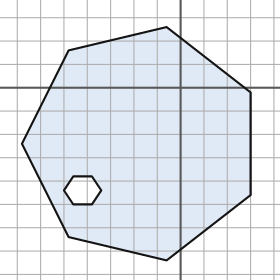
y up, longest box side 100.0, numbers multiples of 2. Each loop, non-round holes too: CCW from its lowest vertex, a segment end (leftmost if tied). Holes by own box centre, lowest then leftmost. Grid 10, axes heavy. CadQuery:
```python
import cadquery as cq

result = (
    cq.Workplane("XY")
    .moveTo(-6.0, -74.0)
    .lineTo(30.0, -46.0)
    .lineTo(30.0, -2.0)
    .lineTo(-6.0, 26.0)
    .lineTo(-48.0, 16.0)
    .lineTo(-68.0, -24.0)
    .lineTo(-48.0, -64.0)
    .close()
    .moveTo(-46.0, -50.0)
    .lineTo(-38.0, -50.0)
    .lineTo(-34.0, -44.0)
    .lineTo(-38.0, -38.0)
    .lineTo(-46.0, -38.0)
    .lineTo(-50.0, -44.0)
    .close()
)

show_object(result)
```